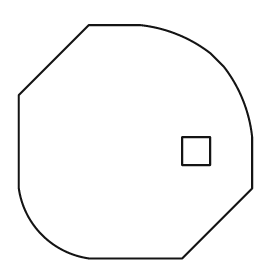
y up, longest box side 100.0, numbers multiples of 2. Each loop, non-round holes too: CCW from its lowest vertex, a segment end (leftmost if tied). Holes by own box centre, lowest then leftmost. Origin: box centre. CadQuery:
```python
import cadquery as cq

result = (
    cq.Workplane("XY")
    .moveTo(-20.0, -50.0)
    .lineTo(20.0, -50.0)
    .lineTo(50.0, -20.0)
    .lineTo(50.0, 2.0)
    .threePointArc((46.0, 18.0), (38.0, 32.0))
    .lineTo(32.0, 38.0)
    .threePointArc((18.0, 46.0), (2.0, 50.0))
    .lineTo(-20.0, 50.0)
    .lineTo(-50.0, 20.0)
    .lineTo(-50.0, -20.0)
    .threePointArc((-40.0, -40.0), (-20.0, -50.0))
    .close()
    .moveTo(20.0, -10.0)
    .lineTo(32.0, -10.0)
    .lineTo(32.0, 2.0)
    .lineTo(20.0, 2.0)
    .close()
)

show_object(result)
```